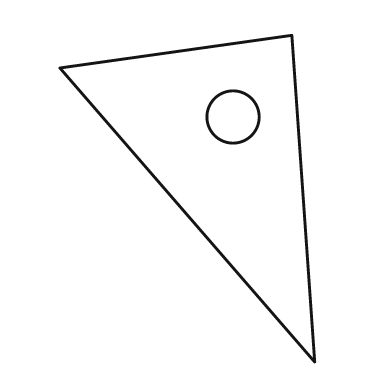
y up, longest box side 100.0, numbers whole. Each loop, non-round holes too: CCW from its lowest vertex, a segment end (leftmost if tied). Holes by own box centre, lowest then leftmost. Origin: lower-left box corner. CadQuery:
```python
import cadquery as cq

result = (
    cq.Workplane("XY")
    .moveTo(78.0, 0.0)
    .lineTo(71.0, 100.0)
    .lineTo(0.0, 90.0)
    .close()
    .moveTo(53.0, 75.0)
    .circle(8.0)
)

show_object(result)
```